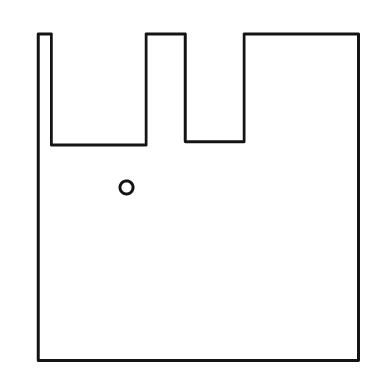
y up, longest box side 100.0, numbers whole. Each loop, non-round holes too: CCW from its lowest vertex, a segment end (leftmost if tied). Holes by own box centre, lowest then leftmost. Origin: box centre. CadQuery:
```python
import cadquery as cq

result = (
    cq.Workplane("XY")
    .moveTo(-49.0, -50.0)
    .lineTo(49.0, -50.0)
    .lineTo(49.0, 50.0)
    .lineTo(14.0, 50.0)
    .lineTo(14.0, 17.0)
    .lineTo(-4.0, 17.0)
    .lineTo(-4.0, 50.0)
    .lineTo(-16.0, 50.0)
    .lineTo(-16.0, 16.0)
    .lineTo(-45.0, 16.0)
    .lineTo(-45.0, 50.0)
    .lineTo(-49.0, 50.0)
    .close()
    .moveTo(-22.0, 3.0)
    .circle(2.0)
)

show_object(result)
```